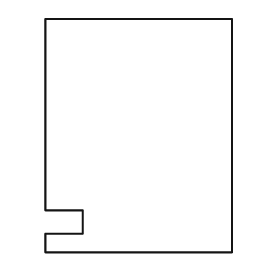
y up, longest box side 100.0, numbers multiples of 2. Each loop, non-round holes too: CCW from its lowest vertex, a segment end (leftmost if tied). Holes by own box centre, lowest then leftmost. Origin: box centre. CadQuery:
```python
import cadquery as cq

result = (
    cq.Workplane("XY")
    .moveTo(-40.0, -50.0)
    .lineTo(40.0, -50.0)
    .lineTo(40.0, 50.0)
    .lineTo(-40.0, 50.0)
    .lineTo(-40.0, -32.0)
    .lineTo(-24.0, -32.0)
    .lineTo(-24.0, -42.0)
    .lineTo(-40.0, -42.0)
    .close()
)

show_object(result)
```